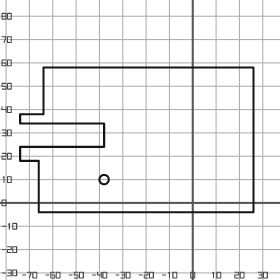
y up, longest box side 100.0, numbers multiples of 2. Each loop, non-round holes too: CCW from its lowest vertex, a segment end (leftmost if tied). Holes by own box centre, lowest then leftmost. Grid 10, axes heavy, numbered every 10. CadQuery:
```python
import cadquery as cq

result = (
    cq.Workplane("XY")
    .moveTo(-66.0, -4.0)
    .lineTo(26.0, -4.0)
    .lineTo(26.0, 58.0)
    .lineTo(-64.0, 58.0)
    .lineTo(-64.0, 38.0)
    .lineTo(-74.0, 38.0)
    .lineTo(-74.0, 34.0)
    .lineTo(-38.0, 34.0)
    .lineTo(-38.0, 24.0)
    .lineTo(-74.0, 24.0)
    .lineTo(-74.0, 18.0)
    .lineTo(-66.0, 18.0)
    .close()
    .moveTo(-38.0, 10.0)
    .circle(2.0)
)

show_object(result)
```